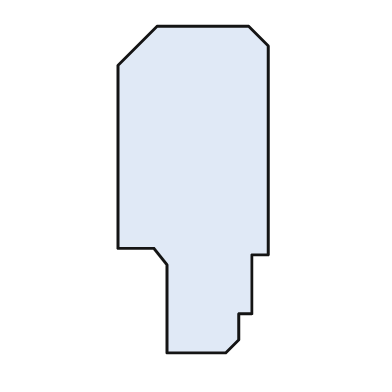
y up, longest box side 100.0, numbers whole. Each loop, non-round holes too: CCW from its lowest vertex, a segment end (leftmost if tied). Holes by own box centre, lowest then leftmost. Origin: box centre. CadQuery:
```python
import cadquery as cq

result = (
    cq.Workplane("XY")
    .moveTo(-8.0, -50.0)
    .lineTo(10.0, -50.0)
    .lineTo(14.0, -46.0)
    .lineTo(14.0, -38.0)
    .lineTo(18.0, -38.0)
    .lineTo(18.0, -20.0)
    .lineTo(23.0, -20.0)
    .lineTo(23.0, 44.0)
    .lineTo(17.0, 50.0)
    .lineTo(-11.0, 50.0)
    .lineTo(-23.0, 38.0)
    .lineTo(-23.0, -18.0)
    .lineTo(-12.0, -18.0)
    .lineTo(-8.0, -23.0)
    .close()
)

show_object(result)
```